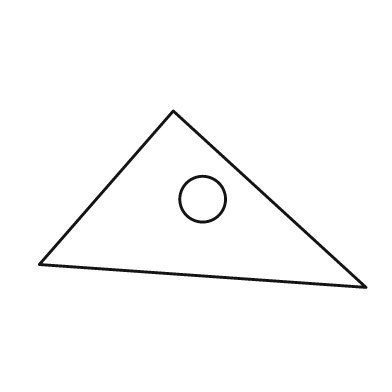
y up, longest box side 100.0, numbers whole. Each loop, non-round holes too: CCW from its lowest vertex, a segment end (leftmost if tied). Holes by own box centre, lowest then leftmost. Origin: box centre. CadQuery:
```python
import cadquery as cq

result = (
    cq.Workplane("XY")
    .moveTo(50.0, -27.0)
    .lineTo(-9.0, 27.0)
    .lineTo(-50.0, -20.0)
    .close()
    .moveTo(0.0, 0.0)
    .circle(7.0)
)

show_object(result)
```